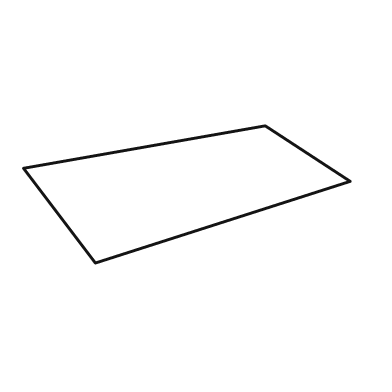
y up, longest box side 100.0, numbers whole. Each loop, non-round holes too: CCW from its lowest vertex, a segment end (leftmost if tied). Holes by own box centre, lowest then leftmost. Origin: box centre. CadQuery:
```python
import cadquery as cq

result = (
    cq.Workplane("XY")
    .moveTo(-28.0, -21.0)
    .lineTo(50.0, 4.0)
    .lineTo(24.0, 21.0)
    .lineTo(-50.0, 8.0)
    .close()
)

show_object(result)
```